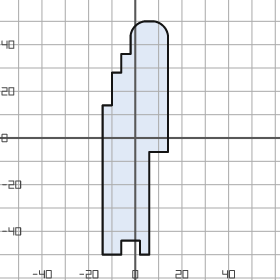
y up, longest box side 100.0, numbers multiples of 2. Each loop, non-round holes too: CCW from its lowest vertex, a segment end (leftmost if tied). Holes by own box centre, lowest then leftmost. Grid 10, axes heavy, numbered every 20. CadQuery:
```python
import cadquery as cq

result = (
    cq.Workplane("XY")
    .moveTo(-14.0, -50.0)
    .lineTo(-6.0, -50.0)
    .lineTo(-6.0, -44.0)
    .lineTo(2.0, -44.0)
    .lineTo(2.0, -50.0)
    .lineTo(6.0, -50.0)
    .lineTo(6.0, -6.0)
    .lineTo(14.0, -6.0)
    .lineTo(14.0, 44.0)
    .threePointArc((12.0, 48.0), (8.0, 50.0))
    .lineTo(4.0, 50.0)
    .threePointArc((0.0, 48.0), (-2.0, 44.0))
    .lineTo(-2.0, 36.0)
    .lineTo(-6.0, 36.0)
    .lineTo(-6.0, 28.0)
    .lineTo(-10.0, 28.0)
    .lineTo(-10.0, 14.0)
    .lineTo(-14.0, 14.0)
    .close()
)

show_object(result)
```